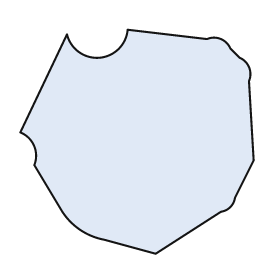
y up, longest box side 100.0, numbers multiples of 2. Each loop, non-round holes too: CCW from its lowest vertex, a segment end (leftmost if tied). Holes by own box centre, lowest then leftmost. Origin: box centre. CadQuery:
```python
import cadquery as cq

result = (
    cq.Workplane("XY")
    .moveTo(8.0, -48.0)
    .lineTo(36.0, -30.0)
    .threePointArc((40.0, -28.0), (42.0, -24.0))
    .lineTo(50.0, -8.0)
    .lineTo(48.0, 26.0)
    .threePointArc((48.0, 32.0), (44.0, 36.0))
    .lineTo(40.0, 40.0)
    .threePointArc((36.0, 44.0), (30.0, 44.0))
    .lineTo(-4.0, 48.0)
    .threePointArc((-16.0, 36.0), (-30.0, 46.0))
    .lineTo(-50.0, 4.0)
    .threePointArc((-44.0, -2.0), (-44.0, -10.0))
    .lineTo(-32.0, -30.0)
    .threePointArc((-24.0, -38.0), (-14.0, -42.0))
    .close()
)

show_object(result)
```